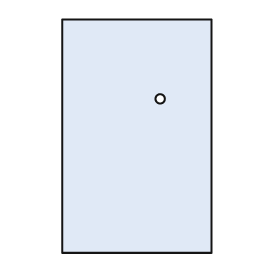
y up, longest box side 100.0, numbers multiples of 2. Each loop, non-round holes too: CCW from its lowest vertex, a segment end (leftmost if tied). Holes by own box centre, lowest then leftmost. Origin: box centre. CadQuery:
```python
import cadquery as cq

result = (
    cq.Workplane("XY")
    .moveTo(-32.0, -50.0)
    .lineTo(32.0, -50.0)
    .lineTo(32.0, 50.0)
    .lineTo(-32.0, 50.0)
    .close()
    .moveTo(10.0, 16.0)
    .circle(2.0)
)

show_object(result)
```